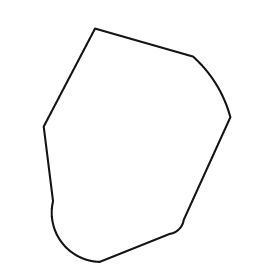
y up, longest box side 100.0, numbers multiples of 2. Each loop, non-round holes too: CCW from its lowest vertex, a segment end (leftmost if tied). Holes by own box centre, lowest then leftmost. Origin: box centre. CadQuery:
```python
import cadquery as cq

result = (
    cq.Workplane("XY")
    .moveTo(-16.0, -50.0)
    .lineTo(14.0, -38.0)
    .threePointArc((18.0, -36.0), (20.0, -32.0))
    .lineTo(40.0, 12.0)
    .threePointArc((34.0, 26.0), (24.0, 38.0))
    .lineTo(-18.0, 50.0)
    .lineTo(-40.0, 8.0)
    .lineTo(-36.0, -24.0)
    .threePointArc((-32.0, -42.0), (-16.0, -50.0))
    .close()
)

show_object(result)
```